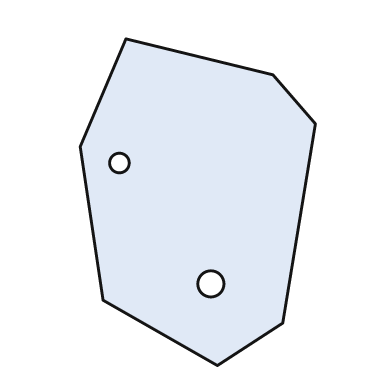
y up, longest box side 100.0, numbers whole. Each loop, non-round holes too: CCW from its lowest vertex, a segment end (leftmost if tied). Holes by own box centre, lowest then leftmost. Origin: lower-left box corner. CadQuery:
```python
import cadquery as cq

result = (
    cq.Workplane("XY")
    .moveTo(42.0, 0.0)
    .lineTo(62.0, 13.0)
    .lineTo(72.0, 74.0)
    .lineTo(59.0, 89.0)
    .lineTo(14.0, 100.0)
    .lineTo(0.0, 67.0)
    .lineTo(7.0, 20.0)
    .close()
    .moveTo(40.0, 25.0)
    .circle(4.0)
    .moveTo(12.0, 62.0)
    .circle(3.0)
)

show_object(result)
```